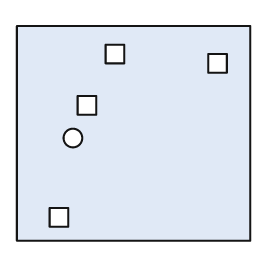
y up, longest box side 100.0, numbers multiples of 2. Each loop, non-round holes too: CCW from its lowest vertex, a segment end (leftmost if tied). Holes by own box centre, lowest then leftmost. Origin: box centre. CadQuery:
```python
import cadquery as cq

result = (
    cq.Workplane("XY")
    .moveTo(-50.0, -46.0)
    .lineTo(50.0, -46.0)
    .lineTo(50.0, 46.0)
    .lineTo(-50.0, 46.0)
    .close()
    .moveTo(-36.0, -40.0)
    .lineTo(-28.0, -40.0)
    .lineTo(-28.0, -32.0)
    .lineTo(-36.0, -32.0)
    .close()
    .moveTo(-26.0, -2.0)
    .circle(4.0)
    .moveTo(-24.0, 8.0)
    .lineTo(-16.0, 8.0)
    .lineTo(-16.0, 16.0)
    .lineTo(-24.0, 16.0)
    .close()
    .moveTo(32.0, 26.0)
    .lineTo(40.0, 26.0)
    .lineTo(40.0, 34.0)
    .lineTo(32.0, 34.0)
    .close()
    .moveTo(-12.0, 30.0)
    .lineTo(-4.0, 30.0)
    .lineTo(-4.0, 38.0)
    .lineTo(-12.0, 38.0)
    .close()
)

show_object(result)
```